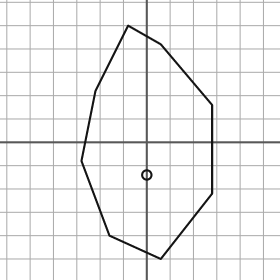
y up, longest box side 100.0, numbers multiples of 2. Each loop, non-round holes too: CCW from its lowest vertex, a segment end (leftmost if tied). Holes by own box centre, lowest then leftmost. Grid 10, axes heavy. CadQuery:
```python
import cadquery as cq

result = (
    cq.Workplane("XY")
    .moveTo(6.0, -50.0)
    .lineTo(28.0, -22.0)
    .lineTo(28.0, 16.0)
    .lineTo(6.0, 42.0)
    .lineTo(-8.0, 50.0)
    .lineTo(-22.0, 22.0)
    .lineTo(-28.0, -8.0)
    .lineTo(-16.0, -40.0)
    .close()
    .moveTo(0.0, -14.0)
    .circle(2.0)
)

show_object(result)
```